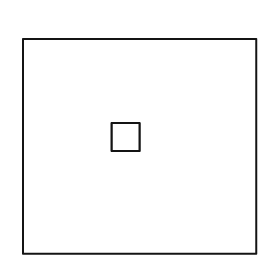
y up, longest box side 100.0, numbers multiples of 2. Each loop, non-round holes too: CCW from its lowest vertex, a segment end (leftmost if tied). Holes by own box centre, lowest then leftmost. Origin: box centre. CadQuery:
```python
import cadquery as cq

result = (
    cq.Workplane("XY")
    .moveTo(-50.0, -46.0)
    .lineTo(50.0, -46.0)
    .lineTo(50.0, 46.0)
    .lineTo(-50.0, 46.0)
    .close()
    .moveTo(-12.0, -2.0)
    .lineTo(0.0, -2.0)
    .lineTo(0.0, 10.0)
    .lineTo(-12.0, 10.0)
    .close()
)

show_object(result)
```